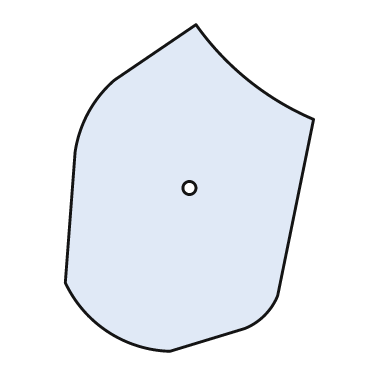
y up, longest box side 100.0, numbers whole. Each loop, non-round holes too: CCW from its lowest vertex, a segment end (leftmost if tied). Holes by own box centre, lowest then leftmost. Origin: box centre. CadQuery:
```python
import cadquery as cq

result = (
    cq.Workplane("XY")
    .moveTo(-6.0, -50.0)
    .lineTo(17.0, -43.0)
    .threePointArc((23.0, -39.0), (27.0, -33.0))
    .lineTo(38.0, 21.0)
    .threePointArc((18.0, 33.0), (2.0, 50.0))
    .lineTo(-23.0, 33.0)
    .threePointArc((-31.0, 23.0), (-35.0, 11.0))
    .lineTo(-38.0, -29.0)
    .threePointArc((-25.0, -44.0), (-6.0, -50.0))
    .close()
    .moveTo(0.0, 0.0)
    .circle(2.0)
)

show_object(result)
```